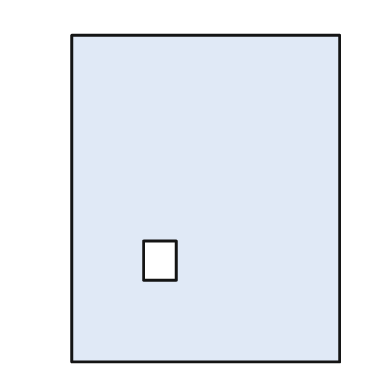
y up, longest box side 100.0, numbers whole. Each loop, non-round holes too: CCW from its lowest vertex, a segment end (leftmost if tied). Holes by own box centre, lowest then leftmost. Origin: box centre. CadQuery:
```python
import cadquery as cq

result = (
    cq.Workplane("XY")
    .moveTo(-41.0, -50.0)
    .lineTo(41.0, -50.0)
    .lineTo(41.0, 50.0)
    .lineTo(-41.0, 50.0)
    .close()
    .moveTo(-19.0, -25.0)
    .lineTo(-9.0, -25.0)
    .lineTo(-9.0, -13.0)
    .lineTo(-19.0, -13.0)
    .close()
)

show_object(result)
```